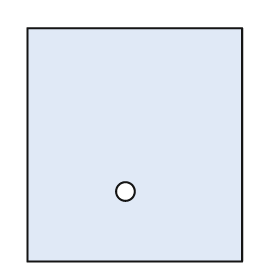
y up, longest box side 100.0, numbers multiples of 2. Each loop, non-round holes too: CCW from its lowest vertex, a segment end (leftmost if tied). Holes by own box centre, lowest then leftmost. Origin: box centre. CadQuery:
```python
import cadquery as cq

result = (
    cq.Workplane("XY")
    .moveTo(-46.0, -50.0)
    .lineTo(46.0, -50.0)
    .lineTo(46.0, 50.0)
    .lineTo(-46.0, 50.0)
    .close()
    .moveTo(-4.0, -20.0)
    .circle(4.0)
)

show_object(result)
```